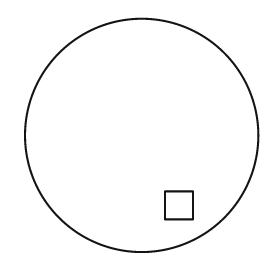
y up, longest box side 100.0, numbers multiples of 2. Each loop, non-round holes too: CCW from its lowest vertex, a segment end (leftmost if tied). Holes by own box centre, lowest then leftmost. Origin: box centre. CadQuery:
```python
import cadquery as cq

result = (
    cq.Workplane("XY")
    .moveTo(0.0, 0.0)
    .circle(50.0)
    .moveTo(10.0, -36.0)
    .lineTo(22.0, -36.0)
    .lineTo(22.0, -24.0)
    .lineTo(10.0, -24.0)
    .close()
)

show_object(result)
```